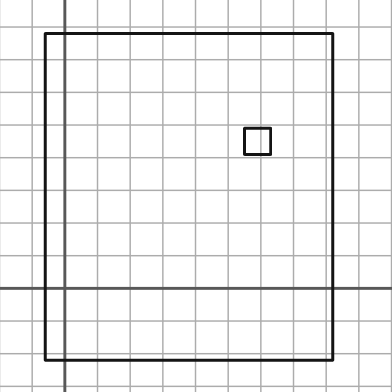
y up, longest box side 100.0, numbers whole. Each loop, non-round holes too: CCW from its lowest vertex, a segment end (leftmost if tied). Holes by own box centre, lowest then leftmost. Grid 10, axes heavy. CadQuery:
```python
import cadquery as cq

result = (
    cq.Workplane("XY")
    .moveTo(-6.0, -22.0)
    .lineTo(82.0, -22.0)
    .lineTo(82.0, 78.0)
    .lineTo(-6.0, 78.0)
    .close()
    .moveTo(55.0, 41.0)
    .lineTo(63.0, 41.0)
    .lineTo(63.0, 49.0)
    .lineTo(55.0, 49.0)
    .close()
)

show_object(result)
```